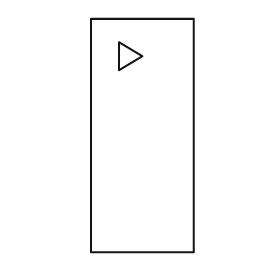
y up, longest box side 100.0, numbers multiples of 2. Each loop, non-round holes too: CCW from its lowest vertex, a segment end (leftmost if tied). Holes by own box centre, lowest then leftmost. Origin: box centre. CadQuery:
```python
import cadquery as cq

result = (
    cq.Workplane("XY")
    .moveTo(-22.0, -50.0)
    .lineTo(22.0, -50.0)
    .lineTo(22.0, 50.0)
    .lineTo(-22.0, 50.0)
    .close()
    .moveTo(-10.0, 28.0)
    .lineTo(0.0, 34.0)
    .lineTo(-10.0, 40.0)
    .close()
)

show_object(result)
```